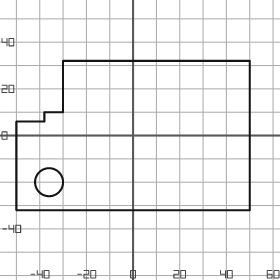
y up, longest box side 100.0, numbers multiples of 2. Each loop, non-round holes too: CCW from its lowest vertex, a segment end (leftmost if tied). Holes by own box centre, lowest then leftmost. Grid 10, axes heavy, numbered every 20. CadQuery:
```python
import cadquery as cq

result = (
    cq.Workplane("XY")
    .moveTo(-50.0, -32.0)
    .lineTo(50.0, -32.0)
    .lineTo(50.0, 32.0)
    .lineTo(-30.0, 32.0)
    .lineTo(-30.0, 10.0)
    .lineTo(-38.0, 10.0)
    .lineTo(-38.0, 6.0)
    .lineTo(-50.0, 6.0)
    .close()
    .moveTo(-36.0, -20.0)
    .circle(6.0)
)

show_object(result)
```